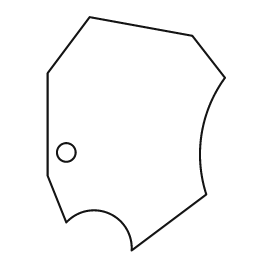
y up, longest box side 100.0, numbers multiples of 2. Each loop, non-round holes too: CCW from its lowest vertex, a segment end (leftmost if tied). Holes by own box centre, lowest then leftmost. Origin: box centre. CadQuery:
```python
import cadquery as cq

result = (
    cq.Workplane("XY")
    .moveTo(-2.0, -50.0)
    .lineTo(30.0, -26.0)
    .threePointArc((28.0, 0.0), (38.0, 24.0))
    .lineTo(24.0, 42.0)
    .lineTo(-20.0, 50.0)
    .lineTo(-38.0, 26.0)
    .lineTo(-38.0, -18.0)
    .lineTo(-30.0, -38.0)
    .threePointArc((-12.0, -34.0), (-2.0, -50.0))
    .close()
    .moveTo(-30.0, -8.0)
    .circle(4.0)
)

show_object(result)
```